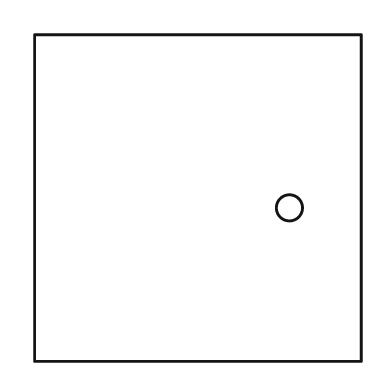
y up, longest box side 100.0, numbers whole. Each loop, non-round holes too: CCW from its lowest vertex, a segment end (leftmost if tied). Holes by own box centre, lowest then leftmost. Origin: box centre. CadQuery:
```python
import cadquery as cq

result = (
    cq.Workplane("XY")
    .moveTo(-50.0, -50.0)
    .lineTo(50.0, -50.0)
    .lineTo(50.0, 50.0)
    .lineTo(-50.0, 50.0)
    .close()
    .moveTo(28.0, -3.0)
    .circle(4.0)
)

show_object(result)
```